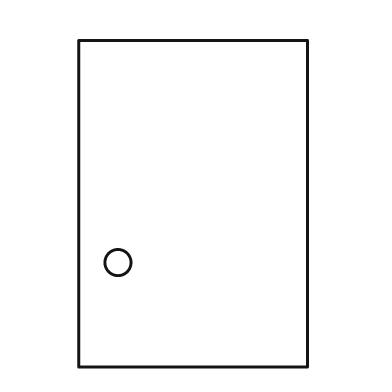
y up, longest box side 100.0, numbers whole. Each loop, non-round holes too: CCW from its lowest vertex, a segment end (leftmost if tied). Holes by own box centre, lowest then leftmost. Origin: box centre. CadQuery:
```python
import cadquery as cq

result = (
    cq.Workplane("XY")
    .moveTo(-35.0, -50.0)
    .lineTo(35.0, -50.0)
    .lineTo(35.0, 50.0)
    .lineTo(-35.0, 50.0)
    .close()
    .moveTo(-23.0, -18.0)
    .circle(4.0)
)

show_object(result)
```